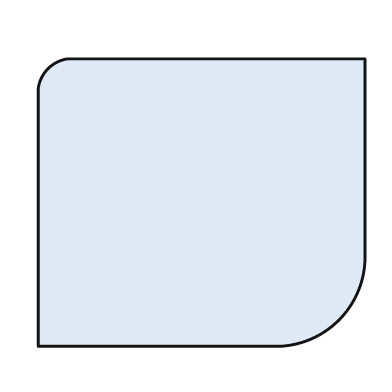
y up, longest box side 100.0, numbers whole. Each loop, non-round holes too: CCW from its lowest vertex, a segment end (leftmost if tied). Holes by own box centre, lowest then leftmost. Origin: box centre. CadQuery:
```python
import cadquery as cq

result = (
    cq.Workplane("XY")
    .moveTo(-50.0, -44.0)
    .lineTo(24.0, -44.0)
    .threePointArc((42.0, -36.0), (50.0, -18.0))
    .lineTo(50.0, 44.0)
    .lineTo(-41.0, 44.0)
    .threePointArc((-47.0, 41.0), (-50.0, 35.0))
    .close()
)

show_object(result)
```